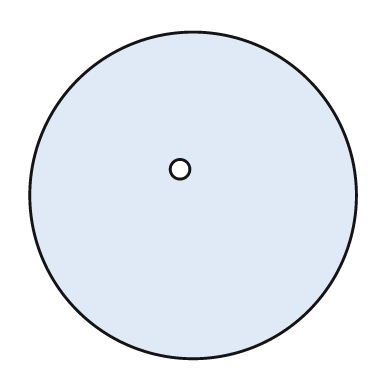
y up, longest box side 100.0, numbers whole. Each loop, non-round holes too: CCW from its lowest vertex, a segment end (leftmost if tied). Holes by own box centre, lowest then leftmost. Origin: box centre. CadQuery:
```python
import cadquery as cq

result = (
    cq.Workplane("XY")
    .moveTo(0.0, 0.0)
    .circle(50.0)
    .moveTo(-4.0, 8.0)
    .circle(3.0)
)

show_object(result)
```